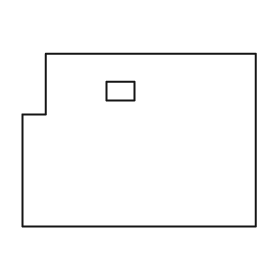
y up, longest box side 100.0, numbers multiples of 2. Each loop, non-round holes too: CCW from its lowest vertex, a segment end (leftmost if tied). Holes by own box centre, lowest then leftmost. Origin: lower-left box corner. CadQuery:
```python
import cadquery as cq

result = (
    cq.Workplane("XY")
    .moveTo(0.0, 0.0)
    .lineTo(100.0, 0.0)
    .lineTo(100.0, 74.0)
    .lineTo(10.0, 74.0)
    .lineTo(10.0, 48.0)
    .lineTo(0.0, 48.0)
    .close()
    .moveTo(36.0, 54.0)
    .lineTo(48.0, 54.0)
    .lineTo(48.0, 62.0)
    .lineTo(36.0, 62.0)
    .close()
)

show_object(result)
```